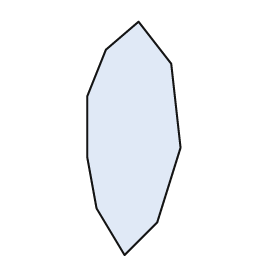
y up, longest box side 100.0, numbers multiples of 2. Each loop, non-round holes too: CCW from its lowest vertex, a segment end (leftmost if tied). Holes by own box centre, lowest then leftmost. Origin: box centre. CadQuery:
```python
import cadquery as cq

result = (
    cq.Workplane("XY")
    .moveTo(-4.0, -50.0)
    .lineTo(10.0, -36.0)
    .lineTo(20.0, -4.0)
    .lineTo(16.0, 32.0)
    .lineTo(2.0, 50.0)
    .lineTo(-12.0, 38.0)
    .lineTo(-20.0, 18.0)
    .lineTo(-20.0, -8.0)
    .lineTo(-16.0, -30.0)
    .close()
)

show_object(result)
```